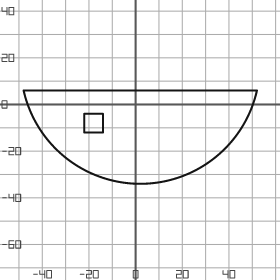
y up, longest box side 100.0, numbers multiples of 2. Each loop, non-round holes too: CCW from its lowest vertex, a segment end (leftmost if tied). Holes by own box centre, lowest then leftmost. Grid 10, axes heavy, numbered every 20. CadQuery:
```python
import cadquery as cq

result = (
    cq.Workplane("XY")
    .moveTo(-48.0, 6.0)
    .threePointArc((2.0, -34.0), (52.0, 6.0))
    .close()
    .moveTo(-22.0, -12.0)
    .lineTo(-14.0, -12.0)
    .lineTo(-14.0, -4.0)
    .lineTo(-22.0, -4.0)
    .close()
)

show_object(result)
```